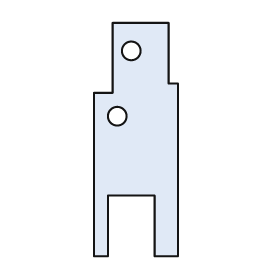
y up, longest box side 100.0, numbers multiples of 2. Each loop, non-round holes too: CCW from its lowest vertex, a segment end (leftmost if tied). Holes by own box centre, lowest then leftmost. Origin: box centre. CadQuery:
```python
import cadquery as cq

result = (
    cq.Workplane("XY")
    .moveTo(-18.0, -50.0)
    .lineTo(-12.0, -50.0)
    .lineTo(-12.0, -24.0)
    .lineTo(8.0, -24.0)
    .lineTo(8.0, -50.0)
    .lineTo(18.0, -50.0)
    .lineTo(18.0, 24.0)
    .lineTo(14.0, 24.0)
    .lineTo(14.0, 50.0)
    .lineTo(-10.0, 50.0)
    .lineTo(-10.0, 20.0)
    .lineTo(-18.0, 20.0)
    .close()
    .moveTo(-8.0, 10.0)
    .circle(4.0)
    .moveTo(-2.0, 38.0)
    .circle(4.0)
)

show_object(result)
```